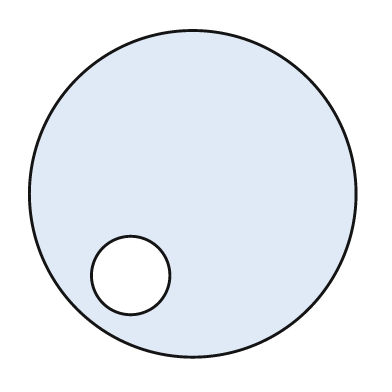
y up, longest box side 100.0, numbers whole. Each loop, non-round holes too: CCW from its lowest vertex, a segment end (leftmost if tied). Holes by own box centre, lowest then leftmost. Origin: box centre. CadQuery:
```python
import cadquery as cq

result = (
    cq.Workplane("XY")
    .moveTo(0.0, 0.0)
    .circle(50.0)
    .moveTo(-19.0, -25.0)
    .circle(12.0)
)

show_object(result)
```